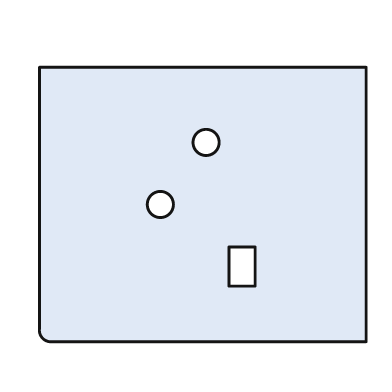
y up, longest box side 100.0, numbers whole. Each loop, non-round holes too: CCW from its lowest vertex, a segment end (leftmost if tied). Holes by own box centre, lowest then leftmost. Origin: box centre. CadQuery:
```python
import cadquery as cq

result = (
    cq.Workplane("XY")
    .moveTo(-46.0, -42.0)
    .lineTo(50.0, -42.0)
    .lineTo(50.0, 42.0)
    .lineTo(-50.0, 42.0)
    .lineTo(-50.0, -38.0)
    .threePointArc((-49.0, -41.0), (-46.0, -42.0))
    .close()
    .moveTo(8.0, -25.0)
    .lineTo(16.0, -25.0)
    .lineTo(16.0, -13.0)
    .lineTo(8.0, -13.0)
    .close()
    .moveTo(-13.0, 0.0)
    .circle(4.0)
    .moveTo(1.0, 19.0)
    .circle(4.0)
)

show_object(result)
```